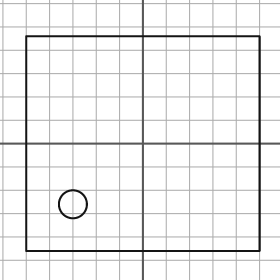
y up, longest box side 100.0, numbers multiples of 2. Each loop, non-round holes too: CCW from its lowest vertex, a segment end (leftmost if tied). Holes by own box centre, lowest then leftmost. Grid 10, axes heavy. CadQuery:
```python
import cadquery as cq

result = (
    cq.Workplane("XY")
    .moveTo(-50.0, -46.0)
    .lineTo(50.0, -46.0)
    .lineTo(50.0, 46.0)
    .lineTo(-50.0, 46.0)
    .close()
    .moveTo(-30.0, -26.0)
    .circle(6.0)
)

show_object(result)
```